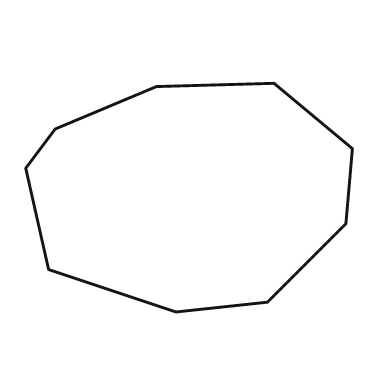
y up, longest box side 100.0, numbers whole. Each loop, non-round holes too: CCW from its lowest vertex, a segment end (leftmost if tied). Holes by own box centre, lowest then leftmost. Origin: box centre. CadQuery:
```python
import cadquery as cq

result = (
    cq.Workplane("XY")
    .moveTo(-4.0, -35.0)
    .lineTo(24.0, -32.0)
    .lineTo(48.0, -8.0)
    .lineTo(50.0, 15.0)
    .lineTo(26.0, 35.0)
    .lineTo(-10.0, 34.0)
    .lineTo(-41.0, 21.0)
    .lineTo(-50.0, 9.0)
    .lineTo(-43.0, -22.0)
    .close()
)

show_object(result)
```